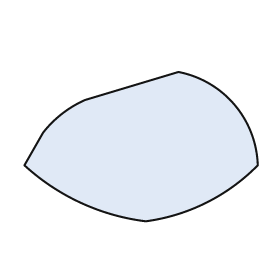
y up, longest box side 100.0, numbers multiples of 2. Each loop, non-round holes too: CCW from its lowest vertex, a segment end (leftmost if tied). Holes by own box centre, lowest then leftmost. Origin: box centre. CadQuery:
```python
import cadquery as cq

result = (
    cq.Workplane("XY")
    .moveTo(2.0, -32.0)
    .threePointArc((28.0, -24.0), (50.0, -8.0))
    .threePointArc((40.0, 18.0), (16.0, 32.0))
    .lineTo(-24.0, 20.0)
    .threePointArc((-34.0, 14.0), (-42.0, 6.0))
    .lineTo(-50.0, -8.0)
    .threePointArc((-26.0, -24.0), (2.0, -32.0))
    .close()
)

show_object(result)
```